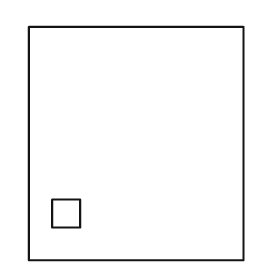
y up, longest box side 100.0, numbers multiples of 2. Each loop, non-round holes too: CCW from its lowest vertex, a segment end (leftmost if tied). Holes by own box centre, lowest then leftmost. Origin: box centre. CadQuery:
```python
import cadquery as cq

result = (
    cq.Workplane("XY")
    .moveTo(-46.0, -50.0)
    .lineTo(46.0, -50.0)
    .lineTo(46.0, 50.0)
    .lineTo(-46.0, 50.0)
    .close()
    .moveTo(-36.0, -36.0)
    .lineTo(-24.0, -36.0)
    .lineTo(-24.0, -24.0)
    .lineTo(-36.0, -24.0)
    .close()
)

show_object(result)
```